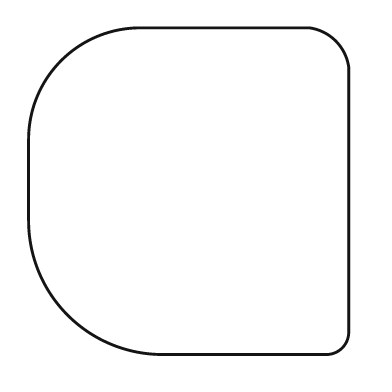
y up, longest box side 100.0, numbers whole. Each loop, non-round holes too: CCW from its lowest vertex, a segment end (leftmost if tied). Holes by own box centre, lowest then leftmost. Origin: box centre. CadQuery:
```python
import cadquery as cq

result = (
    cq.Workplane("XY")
    .moveTo(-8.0, -50.0)
    .lineTo(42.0, -50.0)
    .threePointArc((47.0, -48.0), (49.0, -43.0))
    .lineTo(49.0, 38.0)
    .threePointArc((45.0, 46.0), (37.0, 50.0))
    .lineTo(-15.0, 50.0)
    .threePointArc((-39.0, 40.0), (-49.0, 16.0))
    .lineTo(-49.0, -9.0)
    .threePointArc((-37.0, -38.0), (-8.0, -50.0))
    .close()
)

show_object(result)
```